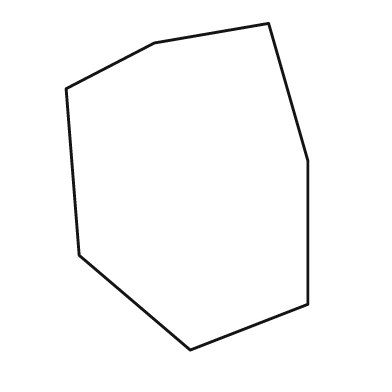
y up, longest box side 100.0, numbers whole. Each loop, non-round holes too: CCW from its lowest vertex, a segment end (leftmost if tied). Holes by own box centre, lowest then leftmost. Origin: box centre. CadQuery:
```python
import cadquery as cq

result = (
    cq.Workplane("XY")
    .moveTo(1.0, -50.0)
    .lineTo(37.0, -36.0)
    .lineTo(37.0, 8.0)
    .lineTo(25.0, 50.0)
    .lineTo(-10.0, 44.0)
    .lineTo(-37.0, 30.0)
    .lineTo(-33.0, -21.0)
    .close()
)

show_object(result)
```